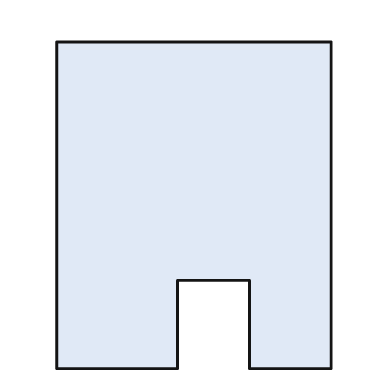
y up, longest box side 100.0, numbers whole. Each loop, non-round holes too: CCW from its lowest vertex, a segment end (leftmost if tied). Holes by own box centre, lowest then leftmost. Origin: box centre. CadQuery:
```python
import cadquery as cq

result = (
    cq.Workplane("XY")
    .moveTo(-42.0, -50.0)
    .lineTo(-5.0, -50.0)
    .lineTo(-5.0, -23.0)
    .lineTo(17.0, -23.0)
    .lineTo(17.0, -50.0)
    .lineTo(42.0, -50.0)
    .lineTo(42.0, 50.0)
    .lineTo(-42.0, 50.0)
    .close()
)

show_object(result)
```